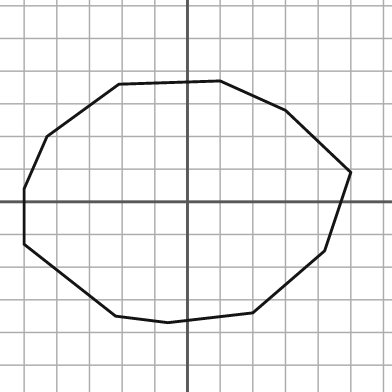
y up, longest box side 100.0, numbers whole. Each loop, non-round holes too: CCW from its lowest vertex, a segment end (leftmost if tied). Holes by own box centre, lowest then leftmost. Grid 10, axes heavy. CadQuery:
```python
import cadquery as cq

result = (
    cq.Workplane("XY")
    .moveTo(-6.0, -37.0)
    .lineTo(20.0, -34.0)
    .lineTo(42.0, -15.0)
    .lineTo(50.0, 9.0)
    .lineTo(30.0, 28.0)
    .lineTo(10.0, 37.0)
    .lineTo(-21.0, 36.0)
    .lineTo(-43.0, 20.0)
    .lineTo(-50.0, 4.0)
    .lineTo(-50.0, -13.0)
    .lineTo(-22.0, -35.0)
    .close()
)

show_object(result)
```